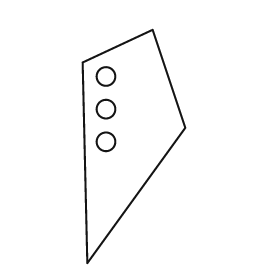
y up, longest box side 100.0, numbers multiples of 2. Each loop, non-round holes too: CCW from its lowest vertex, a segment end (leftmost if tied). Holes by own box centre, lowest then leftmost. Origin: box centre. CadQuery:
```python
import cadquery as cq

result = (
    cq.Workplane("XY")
    .moveTo(-20.0, -50.0)
    .lineTo(22.0, 8.0)
    .lineTo(8.0, 50.0)
    .lineTo(-22.0, 36.0)
    .close()
    .moveTo(-12.0, 2.0)
    .circle(4.0)
    .moveTo(-12.0, 16.0)
    .circle(4.0)
    .moveTo(-12.0, 30.0)
    .circle(4.0)
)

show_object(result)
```